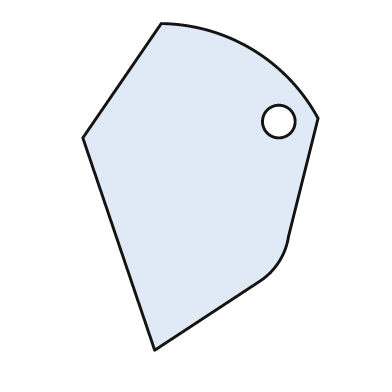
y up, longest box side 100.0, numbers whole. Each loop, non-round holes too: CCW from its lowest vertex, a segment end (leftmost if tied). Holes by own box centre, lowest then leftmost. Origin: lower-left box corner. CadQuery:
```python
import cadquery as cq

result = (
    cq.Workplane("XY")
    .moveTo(22.0, 0.0)
    .lineTo(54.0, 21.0)
    .threePointArc((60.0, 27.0), (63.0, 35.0))
    .lineTo(72.0, 71.0)
    .threePointArc((52.0, 92.0), (24.0, 100.0))
    .lineTo(0.0, 65.0)
    .close()
    .moveTo(60.0, 70.0)
    .circle(5.0)
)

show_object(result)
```